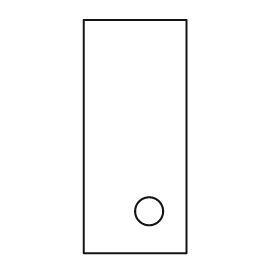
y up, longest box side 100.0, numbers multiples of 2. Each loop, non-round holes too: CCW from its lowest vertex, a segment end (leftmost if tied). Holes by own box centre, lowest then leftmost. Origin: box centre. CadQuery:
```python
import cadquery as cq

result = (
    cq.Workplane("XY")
    .moveTo(-22.0, -50.0)
    .lineTo(22.0, -50.0)
    .lineTo(22.0, 50.0)
    .lineTo(-22.0, 50.0)
    .close()
    .moveTo(6.0, -32.0)
    .circle(6.0)
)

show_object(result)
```